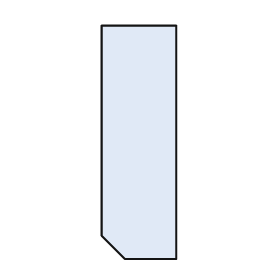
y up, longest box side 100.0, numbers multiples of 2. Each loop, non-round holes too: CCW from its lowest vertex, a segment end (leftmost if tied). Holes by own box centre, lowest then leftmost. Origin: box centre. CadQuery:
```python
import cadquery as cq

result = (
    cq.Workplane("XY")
    .moveTo(-6.0, -50.0)
    .lineTo(16.0, -50.0)
    .lineTo(16.0, 50.0)
    .lineTo(-16.0, 50.0)
    .lineTo(-16.0, -40.0)
    .close()
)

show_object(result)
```